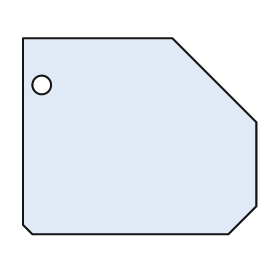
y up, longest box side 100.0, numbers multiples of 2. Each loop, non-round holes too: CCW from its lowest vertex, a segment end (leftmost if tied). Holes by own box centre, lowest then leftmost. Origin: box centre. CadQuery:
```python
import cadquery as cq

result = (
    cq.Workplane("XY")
    .moveTo(-46.0, -42.0)
    .lineTo(38.0, -42.0)
    .lineTo(50.0, -30.0)
    .lineTo(50.0, 6.0)
    .lineTo(14.0, 42.0)
    .lineTo(-50.0, 42.0)
    .lineTo(-50.0, -38.0)
    .close()
    .moveTo(-42.0, 22.0)
    .circle(4.0)
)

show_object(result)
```